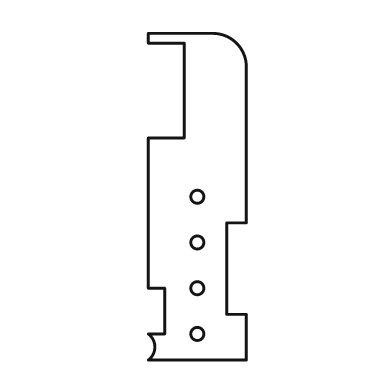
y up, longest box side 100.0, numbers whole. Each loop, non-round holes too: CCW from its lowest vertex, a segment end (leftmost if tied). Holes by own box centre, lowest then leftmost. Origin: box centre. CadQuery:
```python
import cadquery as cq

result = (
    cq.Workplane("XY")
    .moveTo(-15.0, -50.0)
    .lineTo(15.0, -50.0)
    .lineTo(15.0, -36.0)
    .lineTo(9.0, -36.0)
    .lineTo(9.0, -8.0)
    .lineTo(15.0, -8.0)
    .lineTo(15.0, 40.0)
    .threePointArc((12.0, 47.0), (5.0, 50.0))
    .lineTo(-15.0, 50.0)
    .lineTo(-15.0, 47.0)
    .lineTo(-4.0, 47.0)
    .lineTo(-4.0, 18.0)
    .lineTo(-15.0, 18.0)
    .lineTo(-15.0, -28.0)
    .lineTo(-10.0, -28.0)
    .lineTo(-10.0, -42.0)
    .lineTo(-15.0, -42.0)
    .threePointArc((-13.0, -46.0), (-15.0, -50.0))
    .close()
    .moveTo(0.0, -42.0)
    .circle(2.0)
    .moveTo(0.0, -28.0)
    .circle(2.0)
    .moveTo(0.0, -14.0)
    .circle(2.0)
    .moveTo(0.0, 0.0)
    .circle(2.0)
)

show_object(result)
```